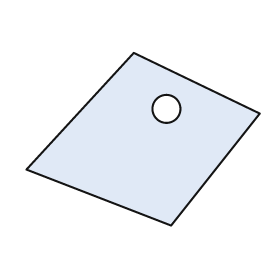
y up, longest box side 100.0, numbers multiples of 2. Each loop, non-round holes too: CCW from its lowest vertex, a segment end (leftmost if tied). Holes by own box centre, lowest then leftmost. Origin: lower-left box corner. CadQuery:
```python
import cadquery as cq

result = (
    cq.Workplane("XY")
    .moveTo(62.0, 0.0)
    .lineTo(100.0, 48.0)
    .lineTo(46.0, 74.0)
    .lineTo(0.0, 24.0)
    .close()
    .moveTo(60.0, 50.0)
    .circle(6.0)
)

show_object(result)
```